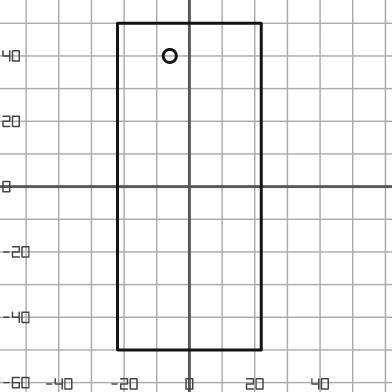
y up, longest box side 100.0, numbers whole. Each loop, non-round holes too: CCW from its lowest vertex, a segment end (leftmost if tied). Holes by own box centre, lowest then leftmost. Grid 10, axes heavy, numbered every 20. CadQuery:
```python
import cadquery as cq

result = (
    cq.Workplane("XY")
    .moveTo(-22.0, -50.0)
    .lineTo(22.0, -50.0)
    .lineTo(22.0, 50.0)
    .lineTo(-22.0, 50.0)
    .close()
    .moveTo(-6.0, 40.0)
    .circle(2.0)
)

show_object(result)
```